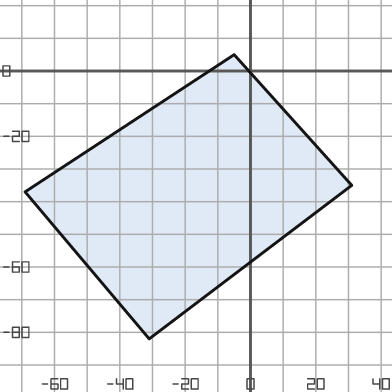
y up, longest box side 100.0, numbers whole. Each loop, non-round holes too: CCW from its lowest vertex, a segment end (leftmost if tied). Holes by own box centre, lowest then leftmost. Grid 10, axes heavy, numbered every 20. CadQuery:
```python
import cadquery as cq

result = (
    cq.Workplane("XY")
    .moveTo(-31.0, -82.0)
    .lineTo(31.0, -35.0)
    .lineTo(-5.0, 5.0)
    .lineTo(-69.0, -37.0)
    .close()
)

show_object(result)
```